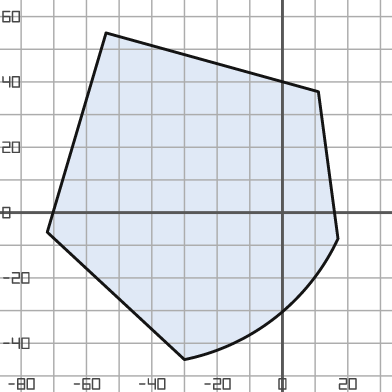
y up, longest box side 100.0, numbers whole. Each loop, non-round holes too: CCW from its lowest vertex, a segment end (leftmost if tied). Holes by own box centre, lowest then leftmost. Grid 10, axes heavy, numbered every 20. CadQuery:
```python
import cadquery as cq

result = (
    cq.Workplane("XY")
    .moveTo(-30.0, -45.0)
    .threePointArc((-2.0, -32.0), (17.0, -8.0))
    .lineTo(11.0, 37.0)
    .lineTo(-54.0, 55.0)
    .lineTo(-72.0, -6.0)
    .close()
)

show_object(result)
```